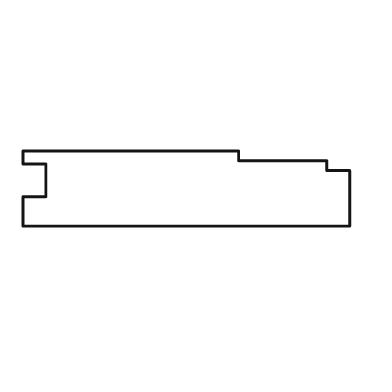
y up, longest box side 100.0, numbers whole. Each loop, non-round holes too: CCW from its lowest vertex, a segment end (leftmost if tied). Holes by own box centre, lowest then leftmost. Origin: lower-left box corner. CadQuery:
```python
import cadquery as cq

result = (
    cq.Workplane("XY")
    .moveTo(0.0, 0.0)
    .lineTo(100.0, 0.0)
    .lineTo(100.0, 17.0)
    .lineTo(93.0, 17.0)
    .lineTo(93.0, 20.0)
    .lineTo(66.0, 20.0)
    .lineTo(66.0, 23.0)
    .lineTo(0.0, 23.0)
    .lineTo(0.0, 19.0)
    .lineTo(7.0, 19.0)
    .lineTo(7.0, 9.0)
    .lineTo(0.0, 9.0)
    .close()
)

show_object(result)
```